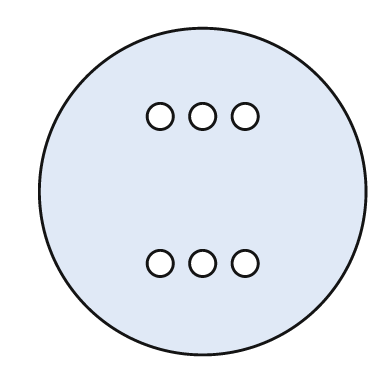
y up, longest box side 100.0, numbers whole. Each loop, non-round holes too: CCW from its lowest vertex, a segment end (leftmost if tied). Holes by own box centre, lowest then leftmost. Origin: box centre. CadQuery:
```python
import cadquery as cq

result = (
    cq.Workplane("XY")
    .moveTo(0.0, 0.0)
    .circle(50.0)
    .moveTo(-13.0, -22.0)
    .circle(4.0)
    .moveTo(0.0, -22.0)
    .circle(4.0)
    .moveTo(13.0, -22.0)
    .circle(4.0)
    .moveTo(-13.0, 23.0)
    .circle(4.0)
    .moveTo(0.0, 23.0)
    .circle(4.0)
    .moveTo(13.0, 23.0)
    .circle(4.0)
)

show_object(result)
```